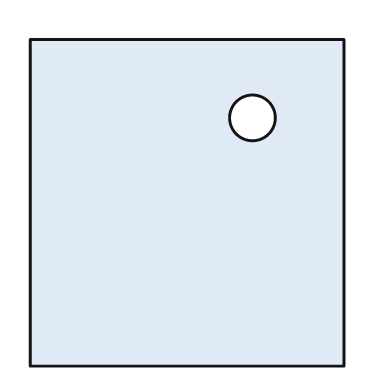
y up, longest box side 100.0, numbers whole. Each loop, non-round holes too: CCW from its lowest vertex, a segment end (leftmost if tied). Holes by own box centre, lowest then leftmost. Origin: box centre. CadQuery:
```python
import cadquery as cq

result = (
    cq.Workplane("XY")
    .moveTo(-48.0, -50.0)
    .lineTo(48.0, -50.0)
    .lineTo(48.0, 50.0)
    .lineTo(-48.0, 50.0)
    .close()
    .moveTo(20.0, 26.0)
    .circle(7.0)
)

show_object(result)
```